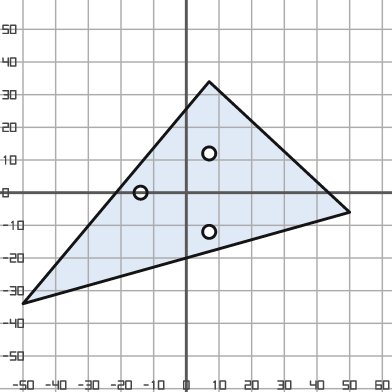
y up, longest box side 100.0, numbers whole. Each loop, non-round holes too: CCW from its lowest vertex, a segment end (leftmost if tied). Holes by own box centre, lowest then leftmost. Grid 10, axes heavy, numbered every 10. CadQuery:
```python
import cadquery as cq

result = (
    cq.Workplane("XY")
    .moveTo(-50.0, -34.0)
    .lineTo(50.0, -6.0)
    .lineTo(7.0, 34.0)
    .close()
    .moveTo(7.0, -12.0)
    .circle(2.0)
    .moveTo(-14.0, 0.0)
    .circle(2.0)
    .moveTo(7.0, 12.0)
    .circle(2.0)
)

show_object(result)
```